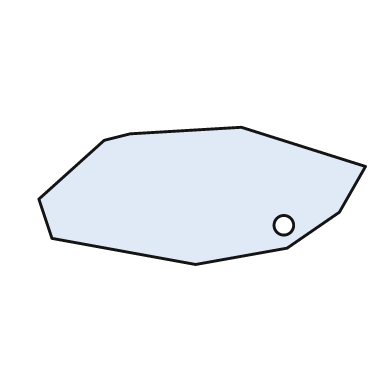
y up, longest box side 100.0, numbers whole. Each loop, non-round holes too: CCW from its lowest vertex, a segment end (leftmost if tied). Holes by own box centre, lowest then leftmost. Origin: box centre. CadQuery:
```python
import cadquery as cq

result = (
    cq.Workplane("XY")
    .moveTo(-2.0, -21.0)
    .lineTo(26.0, -16.0)
    .lineTo(42.0, -5.0)
    .lineTo(50.0, 9.0)
    .lineTo(12.0, 21.0)
    .lineTo(-22.0, 19.0)
    .lineTo(-30.0, 17.0)
    .lineTo(-50.0, -1.0)
    .lineTo(-46.0, -13.0)
    .close()
    .moveTo(25.0, -9.0)
    .circle(3.0)
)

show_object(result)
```